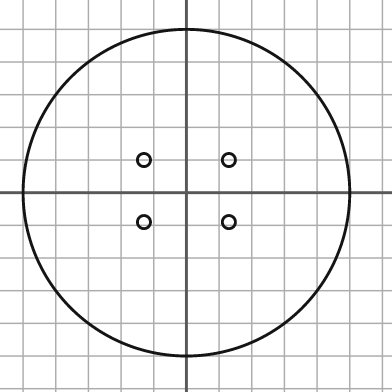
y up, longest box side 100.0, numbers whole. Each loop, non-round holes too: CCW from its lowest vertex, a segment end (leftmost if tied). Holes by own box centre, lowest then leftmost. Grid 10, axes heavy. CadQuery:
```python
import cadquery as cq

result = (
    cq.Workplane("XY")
    .moveTo(0.0, 0.0)
    .circle(50.0)
    .moveTo(-13.0, -9.0)
    .circle(2.0)
    .moveTo(13.0, -9.0)
    .circle(2.0)
    .moveTo(-13.0, 10.0)
    .circle(2.0)
    .moveTo(13.0, 10.0)
    .circle(2.0)
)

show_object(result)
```